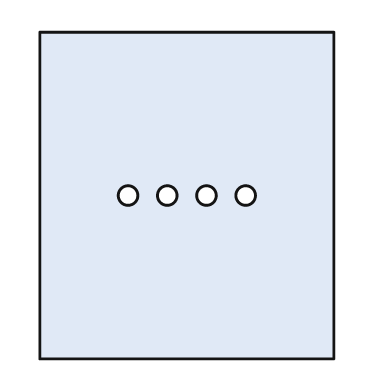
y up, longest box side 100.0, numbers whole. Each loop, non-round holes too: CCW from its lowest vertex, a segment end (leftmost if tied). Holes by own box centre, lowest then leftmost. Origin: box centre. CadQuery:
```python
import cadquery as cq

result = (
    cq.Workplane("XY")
    .moveTo(-45.0, -50.0)
    .lineTo(45.0, -50.0)
    .lineTo(45.0, 50.0)
    .lineTo(-45.0, 50.0)
    .close()
    .moveTo(-18.0, 0.0)
    .circle(3.0)
    .moveTo(-6.0, 0.0)
    .circle(3.0)
    .moveTo(6.0, 0.0)
    .circle(3.0)
    .moveTo(18.0, 0.0)
    .circle(3.0)
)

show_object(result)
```